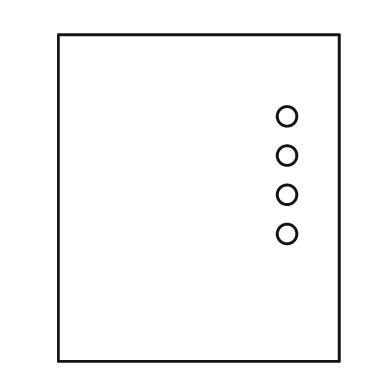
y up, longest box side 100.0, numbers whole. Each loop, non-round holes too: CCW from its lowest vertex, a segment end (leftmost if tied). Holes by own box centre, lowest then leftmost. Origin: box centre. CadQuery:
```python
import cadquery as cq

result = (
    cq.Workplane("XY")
    .moveTo(-43.0, -50.0)
    .lineTo(43.0, -50.0)
    .lineTo(43.0, 50.0)
    .lineTo(-43.0, 50.0)
    .close()
    .moveTo(27.0, -11.0)
    .circle(3.0)
    .moveTo(27.0, 1.0)
    .circle(3.0)
    .moveTo(27.0, 13.0)
    .circle(3.0)
    .moveTo(27.0, 25.0)
    .circle(3.0)
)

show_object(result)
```